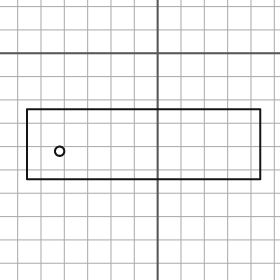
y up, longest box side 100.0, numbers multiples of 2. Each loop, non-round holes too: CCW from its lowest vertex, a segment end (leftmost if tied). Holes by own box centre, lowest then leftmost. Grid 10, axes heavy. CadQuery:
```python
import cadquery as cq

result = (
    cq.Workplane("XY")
    .moveTo(-56.0, -54.0)
    .lineTo(44.0, -54.0)
    .lineTo(44.0, -24.0)
    .lineTo(-56.0, -24.0)
    .close()
    .moveTo(-42.0, -42.0)
    .circle(2.0)
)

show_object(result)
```